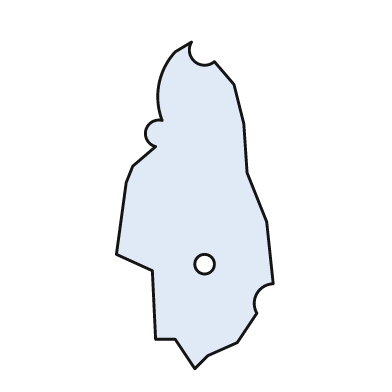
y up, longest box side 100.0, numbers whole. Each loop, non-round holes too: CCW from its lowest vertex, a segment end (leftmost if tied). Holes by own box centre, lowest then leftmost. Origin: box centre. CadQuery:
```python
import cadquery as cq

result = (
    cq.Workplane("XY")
    .moveTo(0.0, -50.0)
    .lineTo(4.0, -46.0)
    .lineTo(13.0, -42.0)
    .lineTo(19.0, -33.0)
    .threePointArc((19.0, -27.0), (24.0, -24.0))
    .lineTo(22.0, -5.0)
    .lineTo(16.0, 10.0)
    .lineTo(15.0, 25.0)
    .lineTo(12.0, 37.0)
    .lineTo(6.0, 44.0)
    .threePointArc((0.0, 44.0), (-1.0, 50.0))
    .lineTo(-6.0, 47.0)
    .threePointArc((-11.0, 37.0), (-10.0, 26.0))
    .threePointArc((-15.0, 23.0), (-12.0, 18.0))
    .lineTo(-19.0, 12.0)
    .lineTo(-21.0, 7.0)
    .lineTo(-24.0, -15.0)
    .lineTo(-13.0, -20.0)
    .lineTo(-12.0, -41.0)
    .lineTo(-6.0, -41.0)
    .close()
    .moveTo(3.0, -18.0)
    .circle(3.0)
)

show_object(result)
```